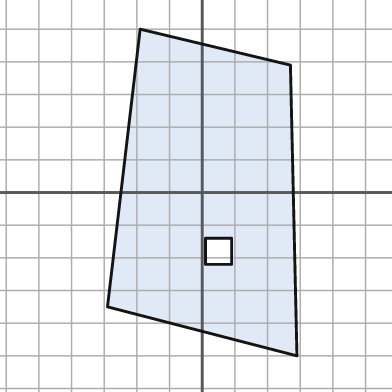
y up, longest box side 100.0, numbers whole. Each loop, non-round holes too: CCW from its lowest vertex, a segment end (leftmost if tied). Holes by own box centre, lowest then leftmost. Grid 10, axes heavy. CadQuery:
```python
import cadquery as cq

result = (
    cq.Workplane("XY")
    .moveTo(29.0, -50.0)
    .lineTo(27.0, 39.0)
    .lineTo(-19.0, 50.0)
    .lineTo(-29.0, -35.0)
    .close()
    .moveTo(1.0, -22.0)
    .lineTo(9.0, -22.0)
    .lineTo(9.0, -14.0)
    .lineTo(1.0, -14.0)
    .close()
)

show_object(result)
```